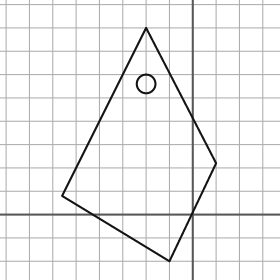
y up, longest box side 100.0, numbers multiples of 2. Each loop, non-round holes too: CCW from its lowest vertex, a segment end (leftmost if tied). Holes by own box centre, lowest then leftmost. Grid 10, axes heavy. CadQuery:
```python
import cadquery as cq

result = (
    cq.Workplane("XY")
    .moveTo(-10.0, -20.0)
    .lineTo(10.0, 22.0)
    .lineTo(-20.0, 80.0)
    .lineTo(-56.0, 8.0)
    .close()
    .moveTo(-20.0, 56.0)
    .circle(4.0)
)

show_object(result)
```